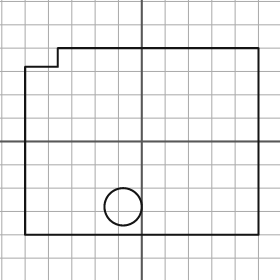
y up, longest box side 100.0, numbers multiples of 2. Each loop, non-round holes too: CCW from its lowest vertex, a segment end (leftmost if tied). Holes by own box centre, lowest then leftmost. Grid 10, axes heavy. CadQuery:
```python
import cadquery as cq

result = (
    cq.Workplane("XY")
    .moveTo(-50.0, -40.0)
    .lineTo(50.0, -40.0)
    .lineTo(50.0, 40.0)
    .lineTo(-36.0, 40.0)
    .lineTo(-36.0, 32.0)
    .lineTo(-50.0, 32.0)
    .close()
    .moveTo(-8.0, -28.0)
    .circle(8.0)
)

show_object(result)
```